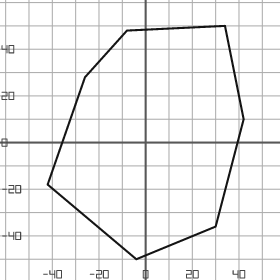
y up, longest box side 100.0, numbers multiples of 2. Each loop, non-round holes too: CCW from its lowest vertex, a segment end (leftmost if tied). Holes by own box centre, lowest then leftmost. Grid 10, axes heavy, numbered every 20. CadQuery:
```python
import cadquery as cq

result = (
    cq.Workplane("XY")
    .moveTo(-4.0, -50.0)
    .lineTo(30.0, -36.0)
    .lineTo(42.0, 10.0)
    .lineTo(34.0, 50.0)
    .lineTo(-8.0, 48.0)
    .lineTo(-26.0, 28.0)
    .lineTo(-42.0, -18.0)
    .close()
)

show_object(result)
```